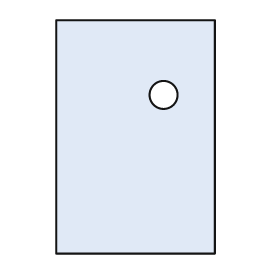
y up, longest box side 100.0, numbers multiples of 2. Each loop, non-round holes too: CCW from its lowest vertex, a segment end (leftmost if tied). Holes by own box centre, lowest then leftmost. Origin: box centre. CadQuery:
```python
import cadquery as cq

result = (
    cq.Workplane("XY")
    .moveTo(-34.0, -50.0)
    .lineTo(34.0, -50.0)
    .lineTo(34.0, 50.0)
    .lineTo(-34.0, 50.0)
    .close()
    .moveTo(12.0, 18.0)
    .circle(6.0)
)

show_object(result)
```